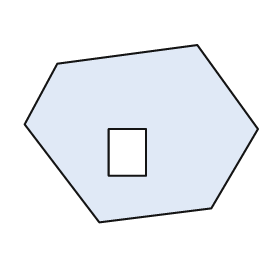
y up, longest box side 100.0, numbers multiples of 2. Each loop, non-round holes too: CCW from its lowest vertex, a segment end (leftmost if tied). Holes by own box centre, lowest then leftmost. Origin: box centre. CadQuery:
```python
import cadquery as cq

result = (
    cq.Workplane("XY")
    .moveTo(-18.0, -38.0)
    .lineTo(30.0, -32.0)
    .lineTo(50.0, 2.0)
    .lineTo(24.0, 38.0)
    .lineTo(-36.0, 30.0)
    .lineTo(-50.0, 4.0)
    .close()
    .moveTo(-14.0, -18.0)
    .lineTo(2.0, -18.0)
    .lineTo(2.0, 2.0)
    .lineTo(-14.0, 2.0)
    .close()
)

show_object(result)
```